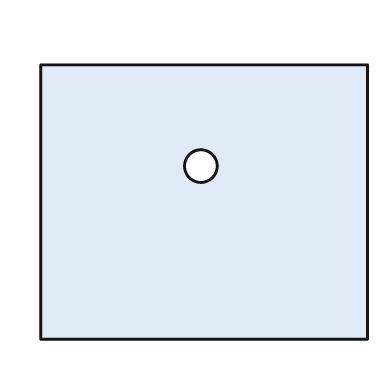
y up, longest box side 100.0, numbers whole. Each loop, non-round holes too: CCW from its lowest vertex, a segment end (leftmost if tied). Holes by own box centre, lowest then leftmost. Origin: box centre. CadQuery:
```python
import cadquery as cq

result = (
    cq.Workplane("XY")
    .moveTo(-50.0, -42.0)
    .lineTo(50.0, -42.0)
    .lineTo(50.0, 42.0)
    .lineTo(-50.0, 42.0)
    .close()
    .moveTo(-1.0, 11.0)
    .circle(5.0)
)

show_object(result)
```